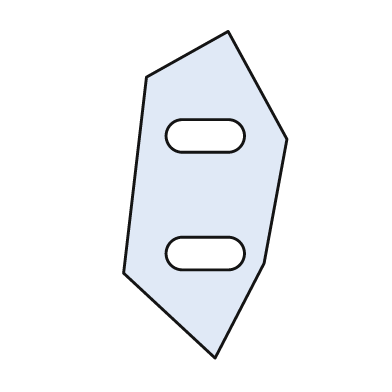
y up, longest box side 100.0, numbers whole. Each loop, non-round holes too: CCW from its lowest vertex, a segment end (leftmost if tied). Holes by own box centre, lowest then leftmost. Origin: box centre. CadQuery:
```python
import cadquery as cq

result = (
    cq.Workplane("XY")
    .moveTo(3.0, -50.0)
    .lineTo(18.0, -21.0)
    .lineTo(25.0, 17.0)
    .lineTo(7.0, 50.0)
    .lineTo(-18.0, 36.0)
    .lineTo(-25.0, -24.0)
    .close()
    .moveTo(-7.0, -23.0)
    .lineTo(7.0, -23.0)
    .threePointArc((12.0, -18.0), (7.0, -13.0))
    .lineTo(-7.0, -13.0)
    .threePointArc((-12.0, -18.0), (-7.0, -23.0))
    .close()
    .moveTo(-7.0, 13.0)
    .lineTo(7.0, 13.0)
    .threePointArc((12.0, 18.0), (7.0, 23.0))
    .lineTo(-7.0, 23.0)
    .threePointArc((-12.0, 18.0), (-7.0, 13.0))
    .close()
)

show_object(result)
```